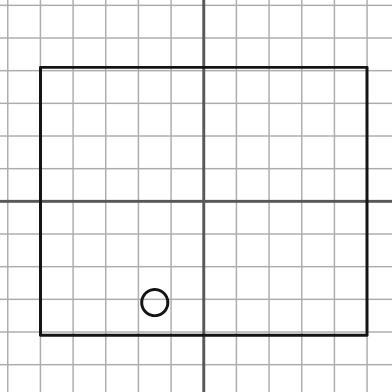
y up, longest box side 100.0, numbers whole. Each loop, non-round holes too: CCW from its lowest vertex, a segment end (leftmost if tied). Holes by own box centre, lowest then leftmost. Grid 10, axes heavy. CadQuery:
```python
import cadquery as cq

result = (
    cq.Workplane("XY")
    .moveTo(-50.0, -41.0)
    .lineTo(50.0, -41.0)
    .lineTo(50.0, 41.0)
    .lineTo(-50.0, 41.0)
    .close()
    .moveTo(-15.0, -31.0)
    .circle(4.0)
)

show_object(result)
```